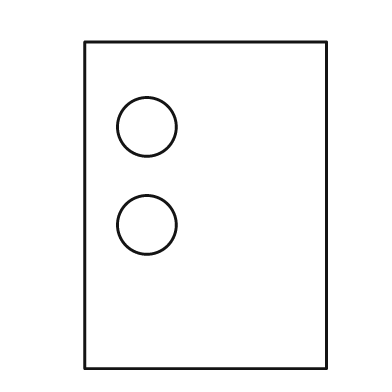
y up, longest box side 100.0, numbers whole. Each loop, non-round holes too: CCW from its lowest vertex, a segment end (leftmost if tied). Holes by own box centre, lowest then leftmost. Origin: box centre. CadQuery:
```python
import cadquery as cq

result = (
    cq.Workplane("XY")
    .moveTo(-37.0, -50.0)
    .lineTo(37.0, -50.0)
    .lineTo(37.0, 50.0)
    .lineTo(-37.0, 50.0)
    .close()
    .moveTo(-18.0, -6.0)
    .circle(9.0)
    .moveTo(-18.0, 24.0)
    .circle(9.0)
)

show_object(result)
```